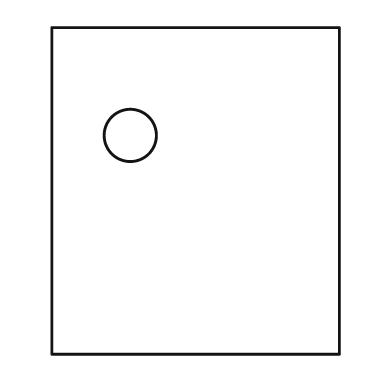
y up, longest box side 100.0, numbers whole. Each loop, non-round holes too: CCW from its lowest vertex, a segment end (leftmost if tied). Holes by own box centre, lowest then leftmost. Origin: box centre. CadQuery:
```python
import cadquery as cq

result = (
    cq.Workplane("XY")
    .moveTo(-44.0, -50.0)
    .lineTo(44.0, -50.0)
    .lineTo(44.0, 50.0)
    .lineTo(-44.0, 50.0)
    .close()
    .moveTo(-20.0, 17.0)
    .circle(8.0)
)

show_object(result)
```